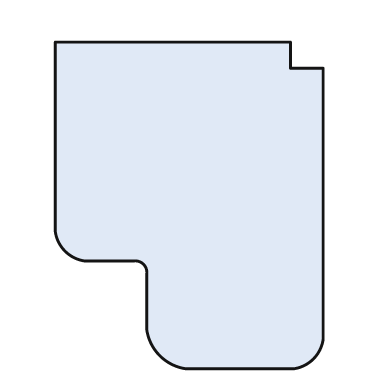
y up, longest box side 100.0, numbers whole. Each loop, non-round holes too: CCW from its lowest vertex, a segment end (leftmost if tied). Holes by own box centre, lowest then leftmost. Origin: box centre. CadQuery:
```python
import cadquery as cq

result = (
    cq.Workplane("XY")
    .moveTo(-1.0, -50.0)
    .lineTo(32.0, -50.0)
    .threePointArc((38.0, -47.0), (41.0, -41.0))
    .lineTo(41.0, 42.0)
    .lineTo(31.0, 42.0)
    .lineTo(31.0, 50.0)
    .lineTo(-41.0, 50.0)
    .lineTo(-41.0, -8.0)
    .threePointArc((-38.0, -14.0), (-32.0, -17.0))
    .lineTo(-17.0, -17.0)
    .threePointArc((-14.0, -18.0), (-13.0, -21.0))
    .lineTo(-13.0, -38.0)
    .threePointArc((-9.0, -46.0), (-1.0, -50.0))
    .close()
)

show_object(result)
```